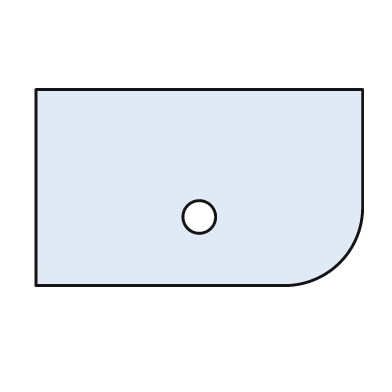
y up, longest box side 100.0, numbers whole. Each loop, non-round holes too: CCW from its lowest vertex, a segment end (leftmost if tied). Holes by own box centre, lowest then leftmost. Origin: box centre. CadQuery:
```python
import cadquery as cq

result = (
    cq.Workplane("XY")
    .moveTo(-50.0, -30.0)
    .lineTo(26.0, -30.0)
    .threePointArc((43.0, -23.0), (50.0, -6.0))
    .lineTo(50.0, 30.0)
    .lineTo(-50.0, 30.0)
    .close()
    .moveTo(0.0, -9.0)
    .circle(5.0)
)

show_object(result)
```